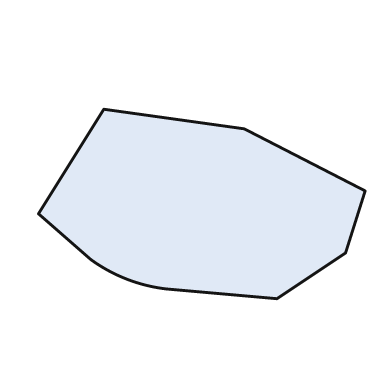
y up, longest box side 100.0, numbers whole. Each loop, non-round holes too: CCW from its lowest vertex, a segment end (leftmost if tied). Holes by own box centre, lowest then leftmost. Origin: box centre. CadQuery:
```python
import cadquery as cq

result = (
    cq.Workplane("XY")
    .moveTo(23.0, -29.0)
    .lineTo(44.0, -15.0)
    .lineTo(50.0, 4.0)
    .lineTo(13.0, 23.0)
    .lineTo(-30.0, 29.0)
    .lineTo(-50.0, -3.0)
    .lineTo(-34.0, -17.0)
    .threePointArc((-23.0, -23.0), (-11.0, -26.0))
    .close()
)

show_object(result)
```